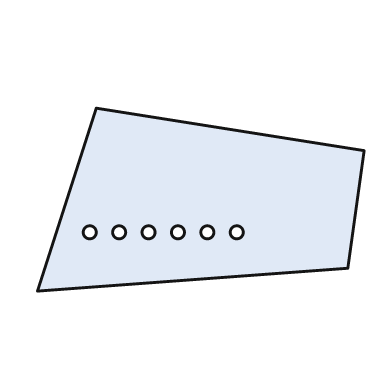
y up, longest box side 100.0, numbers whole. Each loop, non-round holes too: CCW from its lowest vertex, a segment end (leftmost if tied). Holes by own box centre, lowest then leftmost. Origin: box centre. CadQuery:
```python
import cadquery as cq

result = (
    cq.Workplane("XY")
    .moveTo(-50.0, -28.0)
    .lineTo(45.0, -21.0)
    .lineTo(50.0, 15.0)
    .lineTo(-32.0, 28.0)
    .close()
    .moveTo(-34.0, -10.0)
    .circle(2.0)
    .moveTo(-25.0, -10.0)
    .circle(2.0)
    .moveTo(-16.0, -10.0)
    .circle(2.0)
    .moveTo(-7.0, -10.0)
    .circle(2.0)
    .moveTo(2.0, -10.0)
    .circle(2.0)
    .moveTo(11.0, -10.0)
    .circle(2.0)
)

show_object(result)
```